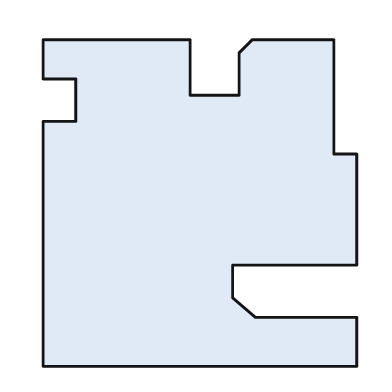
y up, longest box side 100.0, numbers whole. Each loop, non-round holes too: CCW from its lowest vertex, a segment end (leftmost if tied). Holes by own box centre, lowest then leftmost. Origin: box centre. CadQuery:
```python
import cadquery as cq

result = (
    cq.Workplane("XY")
    .moveTo(-48.0, -50.0)
    .lineTo(48.0, -50.0)
    .lineTo(48.0, -35.0)
    .lineTo(17.0, -35.0)
    .lineTo(10.0, -29.0)
    .lineTo(10.0, -19.0)
    .lineTo(48.0, -19.0)
    .lineTo(48.0, 15.0)
    .lineTo(41.0, 15.0)
    .lineTo(41.0, 50.0)
    .lineTo(16.0, 50.0)
    .lineTo(12.0, 46.0)
    .lineTo(12.0, 33.0)
    .lineTo(-3.0, 33.0)
    .lineTo(-3.0, 50.0)
    .lineTo(-48.0, 50.0)
    .lineTo(-48.0, 38.0)
    .lineTo(-38.0, 38.0)
    .lineTo(-38.0, 25.0)
    .lineTo(-48.0, 25.0)
    .close()
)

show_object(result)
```